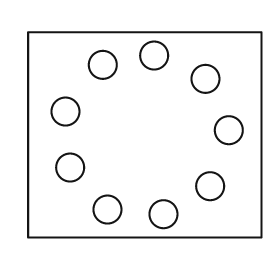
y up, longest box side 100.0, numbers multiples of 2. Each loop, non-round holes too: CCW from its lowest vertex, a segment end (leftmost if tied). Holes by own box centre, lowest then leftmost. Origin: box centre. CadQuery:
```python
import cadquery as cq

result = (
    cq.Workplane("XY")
    .moveTo(-50.0, -44.0)
    .lineTo(50.0, -44.0)
    .lineTo(50.0, 44.0)
    .lineTo(-50.0, 44.0)
    .close()
    .moveTo(8.0, -34.0)
    .circle(6.0)
    .moveTo(-16.0, -32.0)
    .circle(6.0)
    .moveTo(28.0, -22.0)
    .circle(6.0)
    .moveTo(-32.0, -14.0)
    .circle(6.0)
    .moveTo(36.0, 2.0)
    .circle(6.0)
    .moveTo(-34.0, 10.0)
    .circle(6.0)
    .moveTo(26.0, 24.0)
    .circle(6.0)
    .moveTo(-18.0, 30.0)
    .circle(6.0)
    .moveTo(4.0, 34.0)
    .circle(6.0)
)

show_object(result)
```